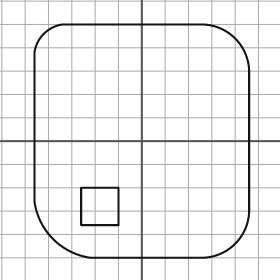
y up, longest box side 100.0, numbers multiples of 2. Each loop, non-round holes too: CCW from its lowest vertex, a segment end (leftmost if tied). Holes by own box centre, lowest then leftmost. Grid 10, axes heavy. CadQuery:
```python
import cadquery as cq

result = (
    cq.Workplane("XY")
    .moveTo(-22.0, -50.0)
    .lineTo(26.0, -50.0)
    .threePointArc((40.0, -44.0), (46.0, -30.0))
    .lineTo(46.0, 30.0)
    .threePointArc((40.0, 44.0), (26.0, 50.0))
    .lineTo(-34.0, 50.0)
    .threePointArc((-42.0, 46.0), (-46.0, 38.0))
    .lineTo(-46.0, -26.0)
    .threePointArc((-38.0, -42.0), (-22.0, -50.0))
    .close()
    .moveTo(-26.0, -36.0)
    .lineTo(-10.0, -36.0)
    .lineTo(-10.0, -20.0)
    .lineTo(-26.0, -20.0)
    .close()
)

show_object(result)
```